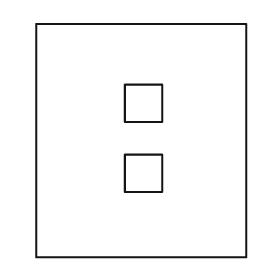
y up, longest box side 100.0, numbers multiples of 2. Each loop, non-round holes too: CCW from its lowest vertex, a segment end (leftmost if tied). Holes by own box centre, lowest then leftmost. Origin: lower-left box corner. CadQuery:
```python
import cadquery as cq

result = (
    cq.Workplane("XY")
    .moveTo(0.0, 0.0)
    .lineTo(90.0, 0.0)
    .lineTo(90.0, 100.0)
    .lineTo(0.0, 100.0)
    .close()
    .moveTo(38.0, 28.0)
    .lineTo(54.0, 28.0)
    .lineTo(54.0, 44.0)
    .lineTo(38.0, 44.0)
    .close()
    .moveTo(38.0, 58.0)
    .lineTo(54.0, 58.0)
    .lineTo(54.0, 74.0)
    .lineTo(38.0, 74.0)
    .close()
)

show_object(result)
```